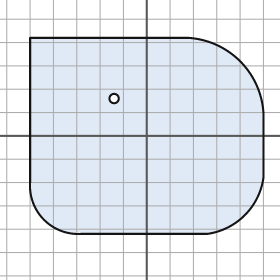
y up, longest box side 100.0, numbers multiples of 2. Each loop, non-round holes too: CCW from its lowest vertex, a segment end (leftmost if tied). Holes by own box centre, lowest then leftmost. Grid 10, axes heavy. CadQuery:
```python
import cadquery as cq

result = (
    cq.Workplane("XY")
    .moveTo(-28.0, -42.0)
    .lineTo(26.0, -42.0)
    .threePointArc((42.0, -34.0), (50.0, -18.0))
    .lineTo(50.0, 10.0)
    .threePointArc((40.0, 32.0), (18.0, 42.0))
    .lineTo(-50.0, 42.0)
    .lineTo(-50.0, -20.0)
    .threePointArc((-44.0, -36.0), (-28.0, -42.0))
    .close()
    .moveTo(-14.0, 16.0)
    .circle(2.0)
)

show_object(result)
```